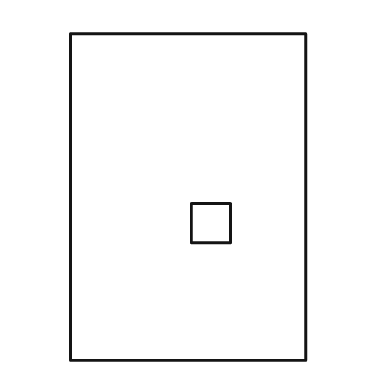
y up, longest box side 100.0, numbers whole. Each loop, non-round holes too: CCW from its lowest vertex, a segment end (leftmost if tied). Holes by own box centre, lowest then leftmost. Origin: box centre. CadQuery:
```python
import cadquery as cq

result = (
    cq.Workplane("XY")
    .moveTo(-36.0, -50.0)
    .lineTo(36.0, -50.0)
    .lineTo(36.0, 50.0)
    .lineTo(-36.0, 50.0)
    .close()
    .moveTo(1.0, -14.0)
    .lineTo(13.0, -14.0)
    .lineTo(13.0, -2.0)
    .lineTo(1.0, -2.0)
    .close()
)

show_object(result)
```